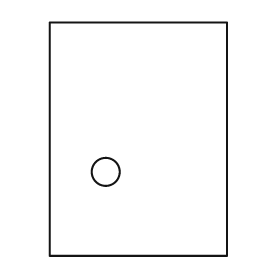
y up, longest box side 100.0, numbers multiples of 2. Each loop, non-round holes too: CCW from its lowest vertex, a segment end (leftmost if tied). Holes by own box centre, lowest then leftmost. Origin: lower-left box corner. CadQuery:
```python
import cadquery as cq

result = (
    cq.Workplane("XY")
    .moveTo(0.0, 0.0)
    .lineTo(76.0, 0.0)
    .lineTo(76.0, 100.0)
    .lineTo(0.0, 100.0)
    .close()
    .moveTo(24.0, 36.0)
    .circle(6.0)
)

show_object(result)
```